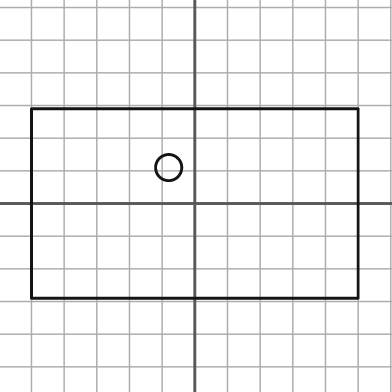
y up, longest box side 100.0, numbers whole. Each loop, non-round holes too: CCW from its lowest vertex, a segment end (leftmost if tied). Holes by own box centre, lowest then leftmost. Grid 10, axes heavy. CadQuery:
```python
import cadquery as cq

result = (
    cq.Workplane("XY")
    .moveTo(-50.0, -29.0)
    .lineTo(50.0, -29.0)
    .lineTo(50.0, 29.0)
    .lineTo(-50.0, 29.0)
    .close()
    .moveTo(-8.0, 11.0)
    .circle(4.0)
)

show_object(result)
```